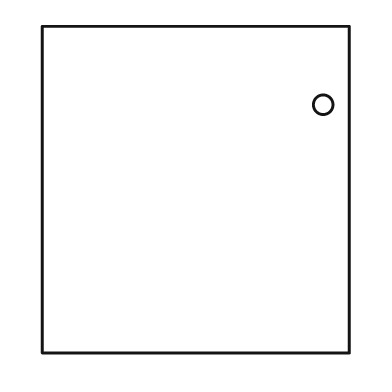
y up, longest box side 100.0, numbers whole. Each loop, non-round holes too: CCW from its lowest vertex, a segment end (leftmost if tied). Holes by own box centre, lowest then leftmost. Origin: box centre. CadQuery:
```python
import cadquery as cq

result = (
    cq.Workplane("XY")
    .moveTo(-47.0, -50.0)
    .lineTo(47.0, -50.0)
    .lineTo(47.0, 50.0)
    .lineTo(-47.0, 50.0)
    .close()
    .moveTo(39.0, 26.0)
    .circle(3.0)
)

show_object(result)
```